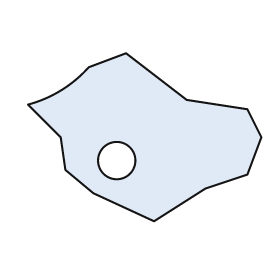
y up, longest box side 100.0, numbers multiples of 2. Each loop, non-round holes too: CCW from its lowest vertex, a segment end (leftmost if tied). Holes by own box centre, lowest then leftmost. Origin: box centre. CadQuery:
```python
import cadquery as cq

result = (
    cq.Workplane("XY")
    .moveTo(4.0, -36.0)
    .lineTo(26.0, -22.0)
    .lineTo(44.0, -16.0)
    .lineTo(50.0, 0.0)
    .lineTo(44.0, 12.0)
    .lineTo(18.0, 16.0)
    .lineTo(-8.0, 36.0)
    .lineTo(-24.0, 30.0)
    .threePointArc((-36.0, 20.0), (-50.0, 14.0))
    .lineTo(-36.0, 0.0)
    .lineTo(-34.0, -14.0)
    .lineTo(-22.0, -24.0)
    .close()
    .moveTo(-12.0, -10.0)
    .circle(8.0)
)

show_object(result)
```